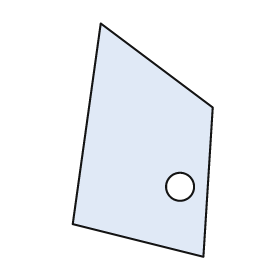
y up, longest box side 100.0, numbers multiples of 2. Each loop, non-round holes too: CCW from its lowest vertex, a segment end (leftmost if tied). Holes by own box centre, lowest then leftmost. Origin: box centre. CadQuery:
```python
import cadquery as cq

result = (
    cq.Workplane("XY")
    .moveTo(26.0, -50.0)
    .lineTo(30.0, 14.0)
    .lineTo(-18.0, 50.0)
    .lineTo(-30.0, -36.0)
    .close()
    .moveTo(16.0, -20.0)
    .circle(6.0)
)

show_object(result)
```